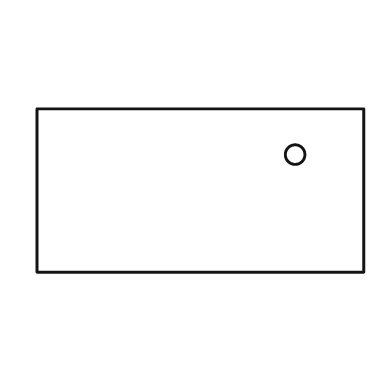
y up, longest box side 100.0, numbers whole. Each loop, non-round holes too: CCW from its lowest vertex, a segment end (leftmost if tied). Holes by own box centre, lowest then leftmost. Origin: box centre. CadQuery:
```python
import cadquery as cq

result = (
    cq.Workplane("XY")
    .moveTo(-50.0, -25.0)
    .lineTo(50.0, -25.0)
    .lineTo(50.0, 25.0)
    .lineTo(-50.0, 25.0)
    .close()
    .moveTo(29.0, 11.0)
    .circle(3.0)
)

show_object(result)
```